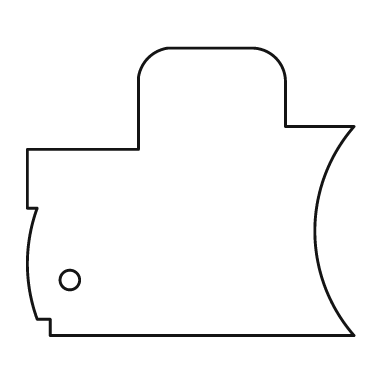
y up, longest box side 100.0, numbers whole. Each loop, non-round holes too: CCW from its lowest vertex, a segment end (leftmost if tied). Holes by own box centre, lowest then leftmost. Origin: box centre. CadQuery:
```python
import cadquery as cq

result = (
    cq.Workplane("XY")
    .moveTo(-43.0, -44.0)
    .lineTo(50.0, -44.0)
    .threePointArc((38.0, -12.0), (50.0, 20.0))
    .lineTo(29.0, 20.0)
    .lineTo(29.0, 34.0)
    .threePointArc((26.0, 41.0), (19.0, 44.0))
    .lineTo(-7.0, 44.0)
    .threePointArc((-13.0, 41.0), (-16.0, 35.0))
    .lineTo(-16.0, 13.0)
    .lineTo(-50.0, 13.0)
    .lineTo(-50.0, -5.0)
    .lineTo(-47.0, -5.0)
    .threePointArc((-50.0, -22.0), (-47.0, -39.0))
    .lineTo(-43.0, -39.0)
    .close()
    .moveTo(-37.0, -27.0)
    .circle(3.0)
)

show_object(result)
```